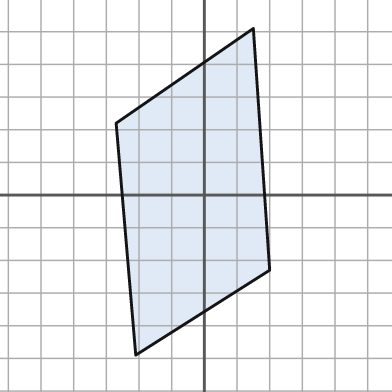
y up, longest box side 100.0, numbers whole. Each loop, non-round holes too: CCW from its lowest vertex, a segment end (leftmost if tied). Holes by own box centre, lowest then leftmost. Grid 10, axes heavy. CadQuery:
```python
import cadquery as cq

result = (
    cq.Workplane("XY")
    .moveTo(-21.0, -49.0)
    .lineTo(20.0, -23.0)
    .lineTo(15.0, 51.0)
    .lineTo(-27.0, 22.0)
    .close()
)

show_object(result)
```